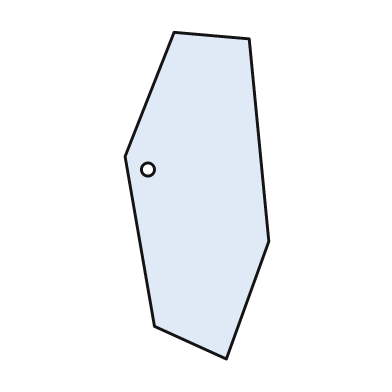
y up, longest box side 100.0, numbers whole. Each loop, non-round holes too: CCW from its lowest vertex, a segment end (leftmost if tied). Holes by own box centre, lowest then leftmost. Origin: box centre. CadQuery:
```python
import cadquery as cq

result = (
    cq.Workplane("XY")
    .moveTo(9.0, -50.0)
    .lineTo(22.0, -14.0)
    .lineTo(16.0, 48.0)
    .lineTo(-7.0, 50.0)
    .lineTo(-22.0, 12.0)
    .lineTo(-13.0, -40.0)
    .close()
    .moveTo(-15.0, 8.0)
    .circle(2.0)
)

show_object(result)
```